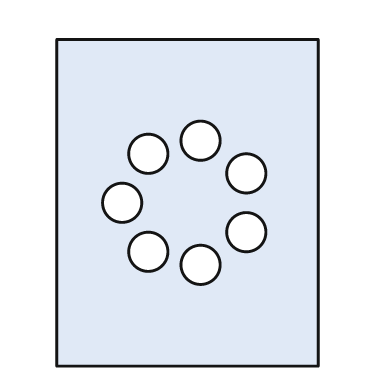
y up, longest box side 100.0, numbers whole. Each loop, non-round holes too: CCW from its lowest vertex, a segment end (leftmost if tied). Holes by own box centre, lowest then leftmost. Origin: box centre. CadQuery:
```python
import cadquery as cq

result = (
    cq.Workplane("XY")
    .moveTo(-40.0, -50.0)
    .lineTo(40.0, -50.0)
    .lineTo(40.0, 50.0)
    .lineTo(-40.0, 50.0)
    .close()
    .moveTo(4.0, -19.0)
    .circle(6.0)
    .moveTo(-12.0, -15.0)
    .circle(6.0)
    .moveTo(18.0, -9.0)
    .circle(6.0)
    .moveTo(-20.0, 0.0)
    .circle(6.0)
    .moveTo(18.0, 9.0)
    .circle(6.0)
    .moveTo(-12.0, 15.0)
    .circle(6.0)
    .moveTo(4.0, 19.0)
    .circle(6.0)
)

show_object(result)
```